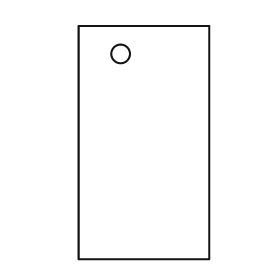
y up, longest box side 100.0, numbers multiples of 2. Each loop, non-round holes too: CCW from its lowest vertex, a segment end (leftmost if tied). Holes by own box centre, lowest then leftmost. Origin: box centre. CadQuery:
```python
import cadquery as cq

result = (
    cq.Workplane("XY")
    .moveTo(-28.0, -50.0)
    .lineTo(28.0, -50.0)
    .lineTo(28.0, 50.0)
    .lineTo(-28.0, 50.0)
    .close()
    .moveTo(-10.0, 38.0)
    .circle(4.0)
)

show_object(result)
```